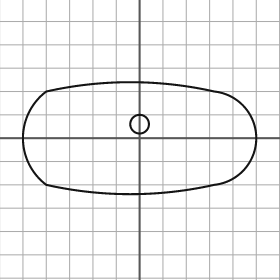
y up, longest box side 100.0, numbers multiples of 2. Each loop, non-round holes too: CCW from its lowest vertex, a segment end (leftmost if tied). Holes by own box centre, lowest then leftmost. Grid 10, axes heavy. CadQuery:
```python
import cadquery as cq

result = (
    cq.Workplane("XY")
    .moveTo(-40.0, -20.0)
    .threePointArc((-4.0, -24.0), (32.0, -20.0))
    .threePointArc((50.0, 0.0), (32.0, 20.0))
    .threePointArc((-4.0, 24.0), (-40.0, 20.0))
    .threePointArc((-50.0, 0.0), (-40.0, -20.0))
    .close()
    .moveTo(0.0, 6.0)
    .circle(4.0)
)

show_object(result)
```